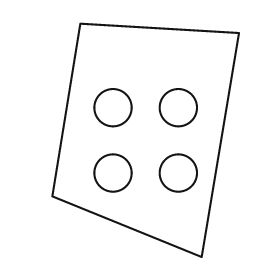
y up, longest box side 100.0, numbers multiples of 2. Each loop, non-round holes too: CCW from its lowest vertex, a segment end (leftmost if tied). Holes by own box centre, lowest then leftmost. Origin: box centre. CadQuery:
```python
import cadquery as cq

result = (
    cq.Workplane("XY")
    .moveTo(24.0, -50.0)
    .lineTo(40.0, 46.0)
    .lineTo(-28.0, 50.0)
    .lineTo(-40.0, -24.0)
    .close()
    .moveTo(-14.0, -14.0)
    .circle(8.0)
    .moveTo(14.0, -14.0)
    .circle(8.0)
    .moveTo(-14.0, 14.0)
    .circle(8.0)
    .moveTo(14.0, 14.0)
    .circle(8.0)
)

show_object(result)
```